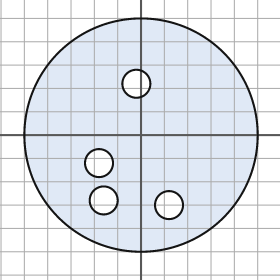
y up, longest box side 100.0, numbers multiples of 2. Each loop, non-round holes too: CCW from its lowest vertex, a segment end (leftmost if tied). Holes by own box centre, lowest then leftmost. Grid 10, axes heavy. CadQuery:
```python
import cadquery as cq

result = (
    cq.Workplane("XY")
    .moveTo(0.0, 0.0)
    .circle(50.0)
    .moveTo(12.0, -30.0)
    .circle(6.0)
    .moveTo(-16.0, -28.0)
    .circle(6.0)
    .moveTo(-18.0, -12.0)
    .circle(6.0)
    .moveTo(-2.0, 22.0)
    .circle(6.0)
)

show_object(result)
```